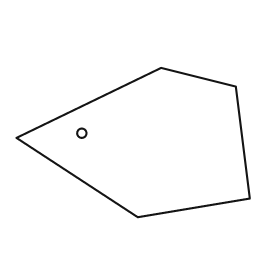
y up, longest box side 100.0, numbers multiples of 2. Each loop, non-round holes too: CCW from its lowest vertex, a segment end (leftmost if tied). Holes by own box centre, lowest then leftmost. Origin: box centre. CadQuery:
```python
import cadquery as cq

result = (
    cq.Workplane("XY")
    .moveTo(2.0, -32.0)
    .lineTo(50.0, -24.0)
    .lineTo(44.0, 24.0)
    .lineTo(12.0, 32.0)
    .lineTo(-50.0, 2.0)
    .close()
    .moveTo(-22.0, 4.0)
    .circle(2.0)
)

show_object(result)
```